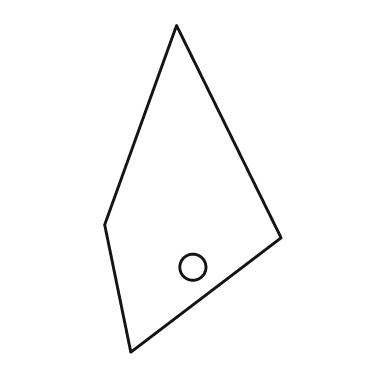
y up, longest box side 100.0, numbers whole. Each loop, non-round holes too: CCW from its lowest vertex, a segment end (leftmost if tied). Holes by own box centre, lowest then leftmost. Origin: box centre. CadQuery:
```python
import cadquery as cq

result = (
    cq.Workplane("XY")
    .moveTo(-19.0, -50.0)
    .lineTo(27.0, -15.0)
    .lineTo(-5.0, 50.0)
    .lineTo(-27.0, -11.0)
    .close()
    .moveTo(0.0, -24.0)
    .circle(4.0)
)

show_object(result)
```